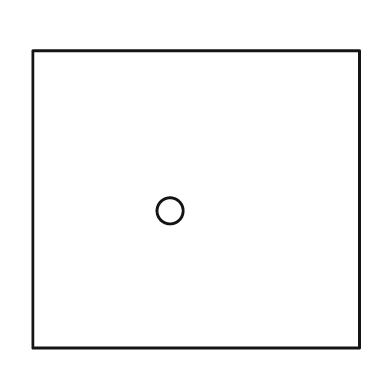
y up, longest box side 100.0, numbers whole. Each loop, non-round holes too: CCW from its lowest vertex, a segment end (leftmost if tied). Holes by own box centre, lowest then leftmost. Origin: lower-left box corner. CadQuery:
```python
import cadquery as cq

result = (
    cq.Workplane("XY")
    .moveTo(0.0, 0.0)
    .lineTo(100.0, 0.0)
    .lineTo(100.0, 91.0)
    .lineTo(0.0, 91.0)
    .close()
    .moveTo(42.0, 42.0)
    .circle(4.0)
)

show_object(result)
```